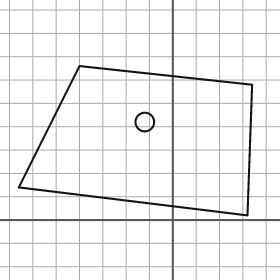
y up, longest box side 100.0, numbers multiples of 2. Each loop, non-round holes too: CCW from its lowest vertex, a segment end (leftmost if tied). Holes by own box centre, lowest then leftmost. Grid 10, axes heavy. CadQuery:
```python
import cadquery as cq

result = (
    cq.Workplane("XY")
    .moveTo(32.0, 2.0)
    .lineTo(34.0, 58.0)
    .lineTo(-40.0, 66.0)
    .lineTo(-66.0, 14.0)
    .close()
    .moveTo(-12.0, 42.0)
    .circle(4.0)
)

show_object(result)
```